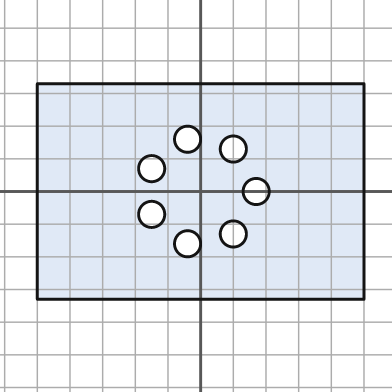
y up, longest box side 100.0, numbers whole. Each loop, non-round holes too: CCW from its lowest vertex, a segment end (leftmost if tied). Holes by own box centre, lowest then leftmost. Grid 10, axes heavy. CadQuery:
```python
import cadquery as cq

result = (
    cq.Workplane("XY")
    .moveTo(-50.0, -33.0)
    .lineTo(50.0, -33.0)
    .lineTo(50.0, 33.0)
    .lineTo(-50.0, 33.0)
    .close()
    .moveTo(-4.0, -16.0)
    .circle(4.0)
    .moveTo(10.0, -13.0)
    .circle(4.0)
    .moveTo(-15.0, -7.0)
    .circle(4.0)
    .moveTo(17.0, 0.0)
    .circle(4.0)
    .moveTo(-15.0, 7.0)
    .circle(4.0)
    .moveTo(10.0, 13.0)
    .circle(4.0)
    .moveTo(-4.0, 16.0)
    .circle(4.0)
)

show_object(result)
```